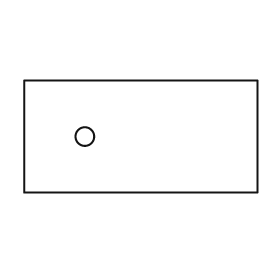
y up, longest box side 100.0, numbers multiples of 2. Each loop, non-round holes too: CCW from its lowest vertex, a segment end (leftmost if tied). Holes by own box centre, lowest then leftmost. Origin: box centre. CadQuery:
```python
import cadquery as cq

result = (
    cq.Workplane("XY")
    .moveTo(-50.0, -24.0)
    .lineTo(50.0, -24.0)
    .lineTo(50.0, 24.0)
    .lineTo(-50.0, 24.0)
    .close()
    .moveTo(-24.0, 0.0)
    .circle(4.0)
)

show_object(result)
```